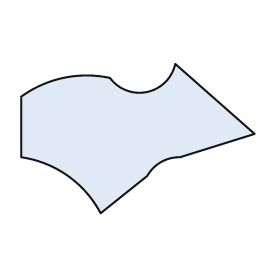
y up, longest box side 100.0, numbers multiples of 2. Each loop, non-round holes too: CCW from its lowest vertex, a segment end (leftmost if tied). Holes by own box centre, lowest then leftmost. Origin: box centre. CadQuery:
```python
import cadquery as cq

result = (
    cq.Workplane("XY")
    .moveTo(-16.0, -32.0)
    .lineTo(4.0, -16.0)
    .threePointArc((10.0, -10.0), (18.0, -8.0))
    .lineTo(50.0, 2.0)
    .lineTo(16.0, 32.0)
    .threePointArc((4.0, 20.0), (-12.0, 26.0))
    .threePointArc((-32.0, 26.0), (-50.0, 18.0))
    .lineTo(-50.0, -8.0)
    .threePointArc((-30.0, -16.0), (-16.0, -32.0))
    .close()
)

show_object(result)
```